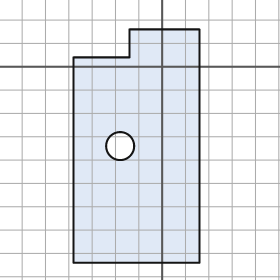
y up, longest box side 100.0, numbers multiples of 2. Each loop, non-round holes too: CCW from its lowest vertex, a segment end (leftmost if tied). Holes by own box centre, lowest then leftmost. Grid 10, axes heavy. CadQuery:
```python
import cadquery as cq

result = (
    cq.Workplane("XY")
    .moveTo(-38.0, -84.0)
    .lineTo(16.0, -84.0)
    .lineTo(16.0, 16.0)
    .lineTo(-14.0, 16.0)
    .lineTo(-14.0, 4.0)
    .lineTo(-38.0, 4.0)
    .close()
    .moveTo(-18.0, -34.0)
    .circle(6.0)
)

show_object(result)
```